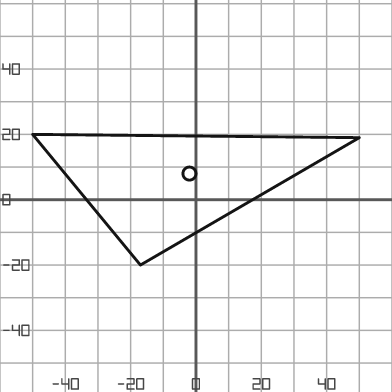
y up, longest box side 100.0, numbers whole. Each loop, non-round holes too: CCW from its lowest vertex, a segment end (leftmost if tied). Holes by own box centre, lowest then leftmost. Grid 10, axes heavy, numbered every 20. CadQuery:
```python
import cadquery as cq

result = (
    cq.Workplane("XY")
    .moveTo(-17.0, -20.0)
    .lineTo(50.0, 19.0)
    .lineTo(-50.0, 20.0)
    .close()
    .moveTo(-2.0, 8.0)
    .circle(2.0)
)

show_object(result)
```